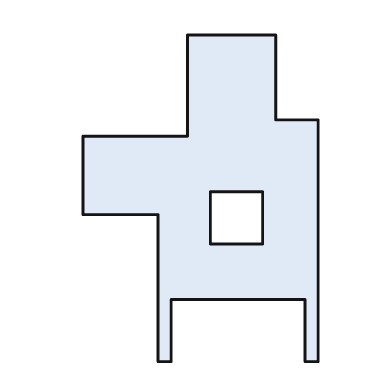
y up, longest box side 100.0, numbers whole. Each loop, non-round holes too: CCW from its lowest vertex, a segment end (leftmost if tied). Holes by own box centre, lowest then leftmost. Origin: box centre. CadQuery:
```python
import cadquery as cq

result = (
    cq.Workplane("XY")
    .moveTo(-13.0, -50.0)
    .lineTo(-9.0, -50.0)
    .lineTo(-9.0, -31.0)
    .lineTo(32.0, -31.0)
    .lineTo(32.0, -50.0)
    .lineTo(36.0, -50.0)
    .lineTo(36.0, 24.0)
    .lineTo(23.0, 24.0)
    .lineTo(23.0, 50.0)
    .lineTo(-4.0, 50.0)
    .lineTo(-4.0, 19.0)
    .lineTo(-36.0, 19.0)
    .lineTo(-36.0, -5.0)
    .lineTo(-13.0, -5.0)
    .close()
    .moveTo(3.0, -14.0)
    .lineTo(19.0, -14.0)
    .lineTo(19.0, 2.0)
    .lineTo(3.0, 2.0)
    .close()
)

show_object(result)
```